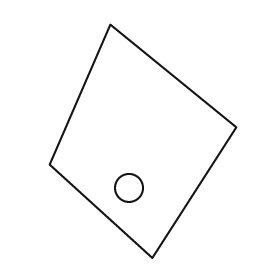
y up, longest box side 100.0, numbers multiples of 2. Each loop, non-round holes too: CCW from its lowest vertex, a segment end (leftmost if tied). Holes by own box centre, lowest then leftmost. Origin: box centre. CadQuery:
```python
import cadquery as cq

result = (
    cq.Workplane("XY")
    .moveTo(4.0, -50.0)
    .lineTo(40.0, 6.0)
    .lineTo(-14.0, 50.0)
    .lineTo(-40.0, -10.0)
    .close()
    .moveTo(-6.0, -20.0)
    .circle(6.0)
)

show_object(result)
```